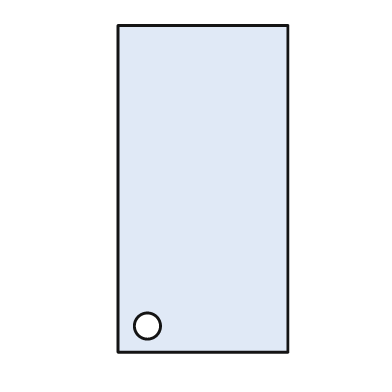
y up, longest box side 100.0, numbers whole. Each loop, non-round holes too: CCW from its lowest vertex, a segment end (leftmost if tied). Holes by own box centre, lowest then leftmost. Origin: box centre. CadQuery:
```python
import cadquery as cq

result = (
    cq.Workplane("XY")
    .moveTo(-26.0, -50.0)
    .lineTo(26.0, -50.0)
    .lineTo(26.0, 50.0)
    .lineTo(-26.0, 50.0)
    .close()
    .moveTo(-17.0, -42.0)
    .circle(4.0)
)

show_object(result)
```